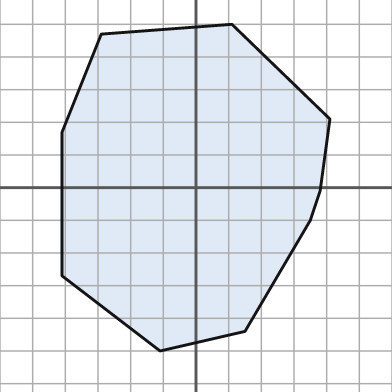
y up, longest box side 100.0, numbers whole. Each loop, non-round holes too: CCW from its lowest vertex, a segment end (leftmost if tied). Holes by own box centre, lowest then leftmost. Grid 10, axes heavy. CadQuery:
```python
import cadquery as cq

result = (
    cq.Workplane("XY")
    .moveTo(-11.0, -50.0)
    .lineTo(15.0, -44.0)
    .lineTo(35.0, -10.0)
    .lineTo(38.0, -1.0)
    .lineTo(41.0, 21.0)
    .lineTo(11.0, 50.0)
    .lineTo(-29.0, 47.0)
    .lineTo(-41.0, 17.0)
    .lineTo(-41.0, -27.0)
    .close()
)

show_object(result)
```